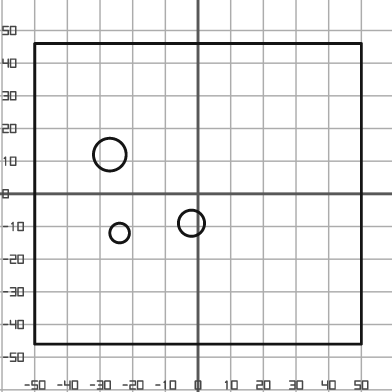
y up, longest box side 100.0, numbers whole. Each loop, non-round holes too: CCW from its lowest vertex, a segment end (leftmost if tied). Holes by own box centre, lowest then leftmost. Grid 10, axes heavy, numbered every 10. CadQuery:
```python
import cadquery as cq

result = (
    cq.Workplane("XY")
    .moveTo(-50.0, -46.0)
    .lineTo(50.0, -46.0)
    .lineTo(50.0, 46.0)
    .lineTo(-50.0, 46.0)
    .close()
    .moveTo(-24.0, -12.0)
    .circle(3.0)
    .moveTo(-2.0, -9.0)
    .circle(4.0)
    .moveTo(-27.0, 12.0)
    .circle(5.0)
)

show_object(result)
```